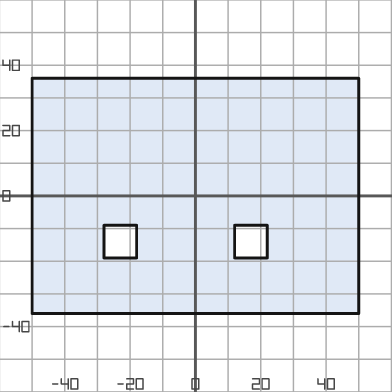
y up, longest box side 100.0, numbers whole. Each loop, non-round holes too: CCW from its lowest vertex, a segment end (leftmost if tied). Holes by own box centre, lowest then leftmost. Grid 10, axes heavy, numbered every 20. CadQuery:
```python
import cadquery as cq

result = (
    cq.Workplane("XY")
    .moveTo(-50.0, -36.0)
    .lineTo(50.0, -36.0)
    .lineTo(50.0, 36.0)
    .lineTo(-50.0, 36.0)
    .close()
    .moveTo(-28.0, -19.0)
    .lineTo(-18.0, -19.0)
    .lineTo(-18.0, -9.0)
    .lineTo(-28.0, -9.0)
    .close()
    .moveTo(12.0, -19.0)
    .lineTo(22.0, -19.0)
    .lineTo(22.0, -9.0)
    .lineTo(12.0, -9.0)
    .close()
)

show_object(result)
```